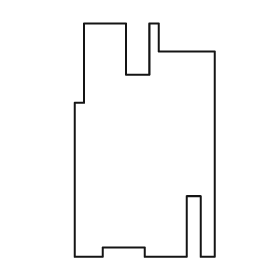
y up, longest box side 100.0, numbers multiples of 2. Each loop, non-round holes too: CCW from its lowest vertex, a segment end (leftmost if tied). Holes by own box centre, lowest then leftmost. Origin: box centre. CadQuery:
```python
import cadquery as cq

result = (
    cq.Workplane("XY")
    .moveTo(-30.0, -50.0)
    .lineTo(-18.0, -50.0)
    .lineTo(-18.0, -46.0)
    .lineTo(0.0, -46.0)
    .lineTo(0.0, -50.0)
    .lineTo(18.0, -50.0)
    .lineTo(18.0, -24.0)
    .lineTo(24.0, -24.0)
    .lineTo(24.0, -50.0)
    .lineTo(30.0, -50.0)
    .lineTo(30.0, 38.0)
    .lineTo(6.0, 38.0)
    .lineTo(6.0, 50.0)
    .lineTo(2.0, 50.0)
    .lineTo(2.0, 28.0)
    .lineTo(-8.0, 28.0)
    .lineTo(-8.0, 50.0)
    .lineTo(-26.0, 50.0)
    .lineTo(-26.0, 16.0)
    .lineTo(-30.0, 16.0)
    .close()
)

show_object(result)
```